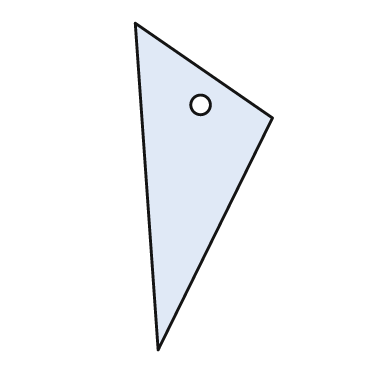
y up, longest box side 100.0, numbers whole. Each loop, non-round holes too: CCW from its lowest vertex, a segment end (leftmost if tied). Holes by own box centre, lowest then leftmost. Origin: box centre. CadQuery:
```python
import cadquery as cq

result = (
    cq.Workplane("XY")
    .moveTo(-14.0, -50.0)
    .lineTo(21.0, 21.0)
    .lineTo(-21.0, 50.0)
    .close()
    .moveTo(-1.0, 25.0)
    .circle(3.0)
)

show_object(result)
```